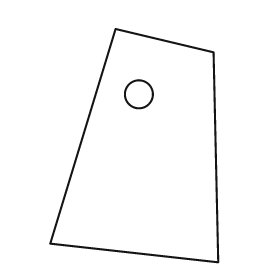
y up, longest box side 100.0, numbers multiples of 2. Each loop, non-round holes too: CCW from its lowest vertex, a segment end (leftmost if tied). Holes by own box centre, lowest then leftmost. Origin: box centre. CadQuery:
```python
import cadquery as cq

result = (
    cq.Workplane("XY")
    .moveTo(36.0, -50.0)
    .lineTo(34.0, 40.0)
    .lineTo(-8.0, 50.0)
    .lineTo(-36.0, -42.0)
    .close()
    .moveTo(2.0, 22.0)
    .circle(6.0)
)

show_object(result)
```